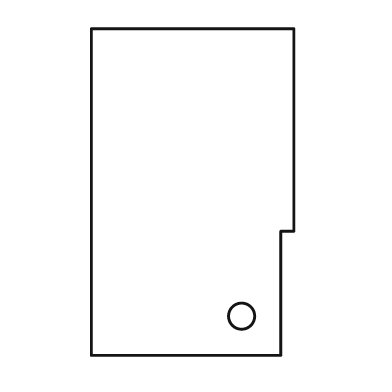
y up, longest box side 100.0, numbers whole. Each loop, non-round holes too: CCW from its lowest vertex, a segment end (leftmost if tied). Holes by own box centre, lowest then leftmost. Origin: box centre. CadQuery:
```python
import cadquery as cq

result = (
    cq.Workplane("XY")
    .moveTo(-31.0, -50.0)
    .lineTo(27.0, -50.0)
    .lineTo(27.0, -12.0)
    .lineTo(31.0, -12.0)
    .lineTo(31.0, 50.0)
    .lineTo(-31.0, 50.0)
    .close()
    .moveTo(15.0, -38.0)
    .circle(4.0)
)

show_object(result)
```